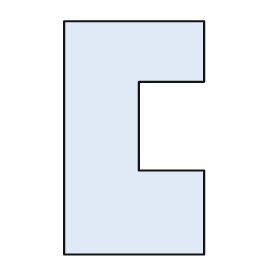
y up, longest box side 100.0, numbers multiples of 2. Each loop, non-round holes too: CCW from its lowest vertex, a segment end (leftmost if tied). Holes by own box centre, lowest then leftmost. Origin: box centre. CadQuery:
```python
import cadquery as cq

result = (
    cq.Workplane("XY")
    .moveTo(-30.0, -50.0)
    .lineTo(30.0, -50.0)
    .lineTo(30.0, -14.0)
    .lineTo(2.0, -14.0)
    .lineTo(2.0, 24.0)
    .lineTo(30.0, 24.0)
    .lineTo(30.0, 50.0)
    .lineTo(-30.0, 50.0)
    .close()
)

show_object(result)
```